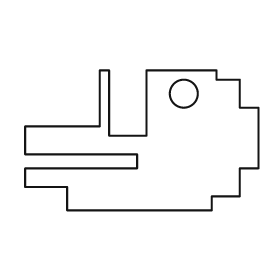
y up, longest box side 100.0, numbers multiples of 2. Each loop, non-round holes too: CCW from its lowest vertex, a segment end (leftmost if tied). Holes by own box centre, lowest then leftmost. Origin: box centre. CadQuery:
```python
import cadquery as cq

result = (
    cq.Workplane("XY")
    .moveTo(-32.0, -30.0)
    .lineTo(30.0, -30.0)
    .lineTo(30.0, -24.0)
    .lineTo(42.0, -24.0)
    .lineTo(42.0, -12.0)
    .lineTo(50.0, -12.0)
    .lineTo(50.0, 14.0)
    .lineTo(42.0, 14.0)
    .lineTo(42.0, 26.0)
    .lineTo(32.0, 26.0)
    .lineTo(32.0, 30.0)
    .lineTo(2.0, 30.0)
    .lineTo(2.0, 2.0)
    .lineTo(-14.0, 2.0)
    .lineTo(-14.0, 30.0)
    .lineTo(-18.0, 30.0)
    .lineTo(-18.0, 6.0)
    .lineTo(-50.0, 6.0)
    .lineTo(-50.0, -6.0)
    .lineTo(-2.0, -6.0)
    .lineTo(-2.0, -12.0)
    .lineTo(-50.0, -12.0)
    .lineTo(-50.0, -20.0)
    .lineTo(-32.0, -20.0)
    .close()
    .moveTo(18.0, 20.0)
    .circle(6.0)
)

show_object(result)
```